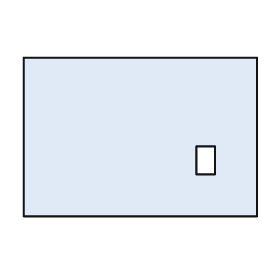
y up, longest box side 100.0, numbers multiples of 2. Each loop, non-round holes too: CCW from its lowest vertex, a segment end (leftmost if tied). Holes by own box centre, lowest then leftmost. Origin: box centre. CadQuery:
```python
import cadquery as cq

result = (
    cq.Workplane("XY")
    .moveTo(-50.0, -34.0)
    .lineTo(50.0, -34.0)
    .lineTo(50.0, 34.0)
    .lineTo(-50.0, 34.0)
    .close()
    .moveTo(24.0, -16.0)
    .lineTo(32.0, -16.0)
    .lineTo(32.0, -4.0)
    .lineTo(24.0, -4.0)
    .close()
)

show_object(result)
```